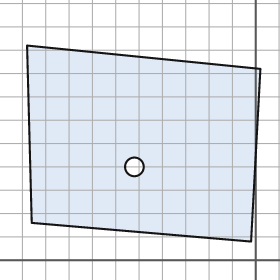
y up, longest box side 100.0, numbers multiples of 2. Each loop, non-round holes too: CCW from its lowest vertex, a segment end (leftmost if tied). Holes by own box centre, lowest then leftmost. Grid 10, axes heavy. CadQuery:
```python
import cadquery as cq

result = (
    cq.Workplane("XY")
    .moveTo(-2.0, 8.0)
    .lineTo(2.0, 82.0)
    .lineTo(-98.0, 92.0)
    .lineTo(-96.0, 16.0)
    .close()
    .moveTo(-52.0, 40.0)
    .circle(4.0)
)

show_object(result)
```